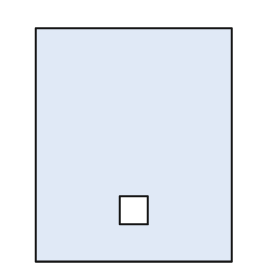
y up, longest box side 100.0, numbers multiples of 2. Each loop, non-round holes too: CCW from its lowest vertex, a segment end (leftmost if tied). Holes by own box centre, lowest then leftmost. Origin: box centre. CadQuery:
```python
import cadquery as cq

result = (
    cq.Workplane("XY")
    .moveTo(-42.0, -50.0)
    .lineTo(42.0, -50.0)
    .lineTo(42.0, 50.0)
    .lineTo(-42.0, 50.0)
    .close()
    .moveTo(-6.0, -34.0)
    .lineTo(6.0, -34.0)
    .lineTo(6.0, -22.0)
    .lineTo(-6.0, -22.0)
    .close()
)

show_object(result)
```